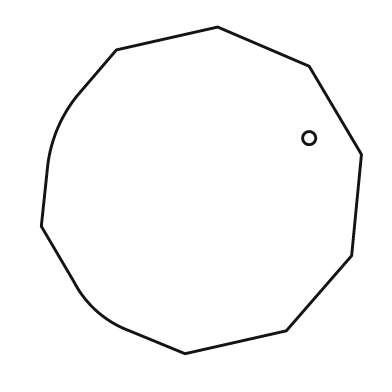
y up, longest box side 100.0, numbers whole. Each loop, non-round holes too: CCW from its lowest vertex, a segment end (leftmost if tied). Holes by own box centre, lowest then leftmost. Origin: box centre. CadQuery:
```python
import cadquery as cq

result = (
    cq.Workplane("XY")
    .moveTo(-5.0, -50.0)
    .lineTo(26.0, -43.0)
    .lineTo(46.0, -20.0)
    .lineTo(49.0, 11.0)
    .lineTo(33.0, 38.0)
    .lineTo(5.0, 50.0)
    .lineTo(-26.0, 43.0)
    .lineTo(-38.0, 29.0)
    .threePointArc((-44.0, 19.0), (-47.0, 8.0))
    .lineTo(-49.0, -11.0)
    .lineTo(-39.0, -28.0)
    .threePointArc((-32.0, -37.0), (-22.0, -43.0))
    .close()
    .moveTo(33.0, 16.0)
    .circle(2.0)
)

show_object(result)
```